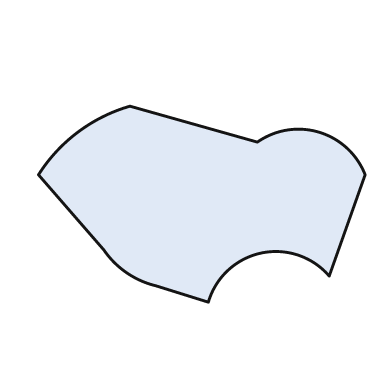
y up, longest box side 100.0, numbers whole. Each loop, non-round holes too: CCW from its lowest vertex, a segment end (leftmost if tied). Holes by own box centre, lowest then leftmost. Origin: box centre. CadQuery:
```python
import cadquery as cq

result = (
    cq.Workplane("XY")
    .moveTo(2.0, -30.0)
    .threePointArc((18.0, -15.0), (39.0, -22.0))
    .lineTo(50.0, 9.0)
    .threePointArc((36.0, 22.0), (17.0, 19.0))
    .lineTo(-22.0, 30.0)
    .threePointArc((-38.0, 22.0), (-50.0, 9.0))
    .lineTo(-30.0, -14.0)
    .threePointArc((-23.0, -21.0), (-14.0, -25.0))
    .close()
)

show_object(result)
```